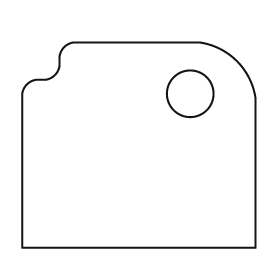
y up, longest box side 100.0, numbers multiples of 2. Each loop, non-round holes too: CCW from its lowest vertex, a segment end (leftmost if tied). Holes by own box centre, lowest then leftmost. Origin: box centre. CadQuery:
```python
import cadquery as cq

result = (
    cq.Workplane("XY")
    .moveTo(-50.0, -44.0)
    .lineTo(50.0, -44.0)
    .lineTo(50.0, 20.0)
    .threePointArc((42.0, 36.0), (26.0, 44.0))
    .lineTo(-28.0, 44.0)
    .threePointArc((-32.0, 42.0), (-34.0, 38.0))
    .lineTo(-34.0, 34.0)
    .threePointArc((-36.0, 30.0), (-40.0, 28.0))
    .lineTo(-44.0, 28.0)
    .threePointArc((-48.0, 26.0), (-50.0, 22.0))
    .close()
    .moveTo(22.0, 22.0)
    .circle(10.0)
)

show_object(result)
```